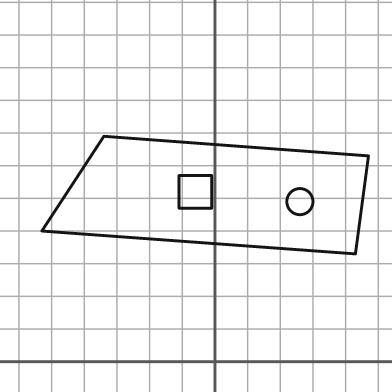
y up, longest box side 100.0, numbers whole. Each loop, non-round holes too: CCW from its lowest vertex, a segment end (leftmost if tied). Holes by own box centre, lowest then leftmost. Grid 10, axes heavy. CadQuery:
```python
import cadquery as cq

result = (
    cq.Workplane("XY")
    .moveTo(43.0, 33.0)
    .lineTo(47.0, 63.0)
    .lineTo(-34.0, 69.0)
    .lineTo(-53.0, 40.0)
    .close()
    .moveTo(26.0, 49.0)
    .circle(4.0)
    .moveTo(-11.0, 47.0)
    .lineTo(-1.0, 47.0)
    .lineTo(-1.0, 57.0)
    .lineTo(-11.0, 57.0)
    .close()
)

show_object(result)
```